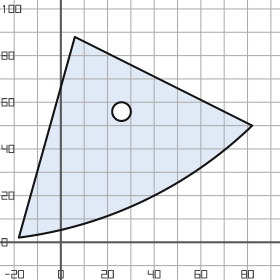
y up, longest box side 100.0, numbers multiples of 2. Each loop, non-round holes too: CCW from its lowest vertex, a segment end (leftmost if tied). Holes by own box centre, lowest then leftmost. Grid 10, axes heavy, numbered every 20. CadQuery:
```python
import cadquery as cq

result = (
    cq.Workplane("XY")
    .moveTo(-18.0, 2.0)
    .threePointArc((36.0, 18.0), (82.0, 50.0))
    .lineTo(6.0, 88.0)
    .close()
    .moveTo(26.0, 56.0)
    .circle(4.0)
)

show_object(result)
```